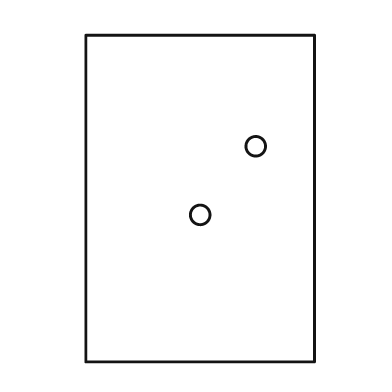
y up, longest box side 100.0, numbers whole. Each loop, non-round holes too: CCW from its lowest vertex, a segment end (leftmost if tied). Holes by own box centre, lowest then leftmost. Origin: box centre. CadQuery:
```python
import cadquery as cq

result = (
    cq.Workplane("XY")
    .moveTo(-35.0, -50.0)
    .lineTo(35.0, -50.0)
    .lineTo(35.0, 50.0)
    .lineTo(-35.0, 50.0)
    .close()
    .moveTo(0.0, -5.0)
    .circle(3.0)
    .moveTo(17.0, 16.0)
    .circle(3.0)
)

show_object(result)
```